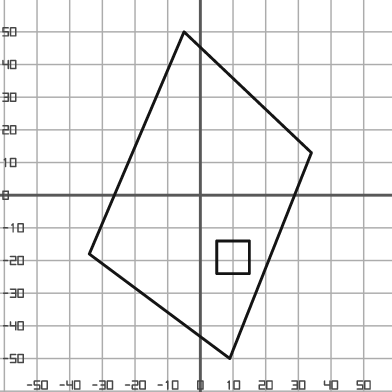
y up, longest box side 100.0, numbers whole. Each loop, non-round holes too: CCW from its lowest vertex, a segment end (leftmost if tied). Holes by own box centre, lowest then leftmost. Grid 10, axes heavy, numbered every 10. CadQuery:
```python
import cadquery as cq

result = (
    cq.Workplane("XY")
    .moveTo(9.0, -50.0)
    .lineTo(34.0, 13.0)
    .lineTo(-5.0, 50.0)
    .lineTo(-34.0, -18.0)
    .close()
    .moveTo(5.0, -24.0)
    .lineTo(15.0, -24.0)
    .lineTo(15.0, -14.0)
    .lineTo(5.0, -14.0)
    .close()
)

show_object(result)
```